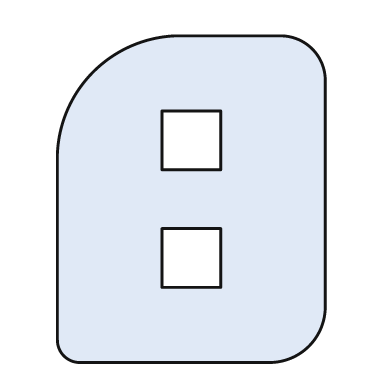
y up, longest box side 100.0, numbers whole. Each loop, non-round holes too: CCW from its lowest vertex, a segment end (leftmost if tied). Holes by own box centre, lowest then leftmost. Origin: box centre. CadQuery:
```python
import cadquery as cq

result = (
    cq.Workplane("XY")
    .moveTo(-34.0, -50.0)
    .lineTo(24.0, -50.0)
    .threePointArc((36.0, -45.0), (41.0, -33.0))
    .lineTo(41.0, 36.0)
    .threePointArc((37.0, 46.0), (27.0, 50.0))
    .lineTo(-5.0, 50.0)
    .threePointArc((-30.0, 39.0), (-41.0, 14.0))
    .lineTo(-41.0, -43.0)
    .threePointArc((-39.0, -48.0), (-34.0, -50.0))
    .close()
    .moveTo(-9.0, -27.0)
    .lineTo(9.0, -27.0)
    .lineTo(9.0, -9.0)
    .lineTo(-9.0, -9.0)
    .close()
    .moveTo(-9.0, 9.0)
    .lineTo(9.0, 9.0)
    .lineTo(9.0, 27.0)
    .lineTo(-9.0, 27.0)
    .close()
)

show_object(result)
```